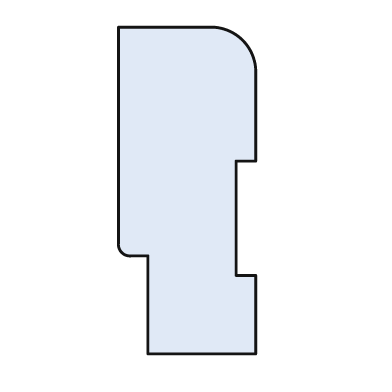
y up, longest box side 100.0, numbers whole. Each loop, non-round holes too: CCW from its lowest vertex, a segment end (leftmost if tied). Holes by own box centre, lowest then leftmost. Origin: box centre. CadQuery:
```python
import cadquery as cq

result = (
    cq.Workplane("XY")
    .moveTo(-12.0, -50.0)
    .lineTo(21.0, -50.0)
    .lineTo(21.0, -26.0)
    .lineTo(15.0, -26.0)
    .lineTo(15.0, 9.0)
    .lineTo(21.0, 9.0)
    .lineTo(21.0, 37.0)
    .threePointArc((17.0, 46.0), (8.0, 50.0))
    .lineTo(-21.0, 50.0)
    .lineTo(-21.0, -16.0)
    .threePointArc((-20.0, -19.0), (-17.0, -20.0))
    .lineTo(-12.0, -20.0)
    .close()
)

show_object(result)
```